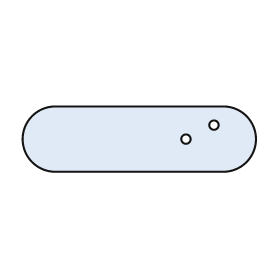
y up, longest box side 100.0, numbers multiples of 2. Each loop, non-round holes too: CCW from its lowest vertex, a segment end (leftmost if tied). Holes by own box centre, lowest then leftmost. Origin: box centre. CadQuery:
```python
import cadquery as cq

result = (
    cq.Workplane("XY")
    .moveTo(-36.0, -14.0)
    .lineTo(36.0, -14.0)
    .threePointArc((50.0, 0.0), (36.0, 14.0))
    .lineTo(-36.0, 14.0)
    .threePointArc((-50.0, 0.0), (-36.0, -14.0))
    .close()
    .moveTo(20.0, 0.0)
    .circle(2.0)
    .moveTo(32.0, 6.0)
    .circle(2.0)
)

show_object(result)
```